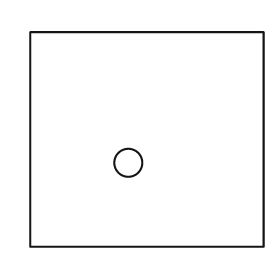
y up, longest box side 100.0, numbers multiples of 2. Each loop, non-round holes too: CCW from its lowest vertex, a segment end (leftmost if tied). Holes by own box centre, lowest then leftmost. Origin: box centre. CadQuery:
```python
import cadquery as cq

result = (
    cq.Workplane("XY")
    .moveTo(-50.0, -46.0)
    .lineTo(50.0, -46.0)
    .lineTo(50.0, 46.0)
    .lineTo(-50.0, 46.0)
    .close()
    .moveTo(-8.0, -10.0)
    .circle(6.0)
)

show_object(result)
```